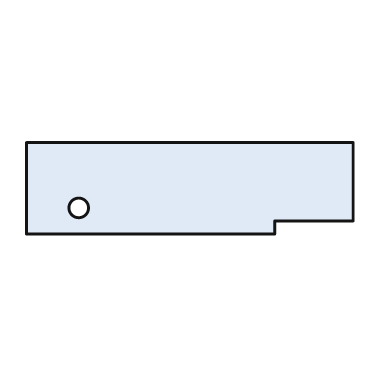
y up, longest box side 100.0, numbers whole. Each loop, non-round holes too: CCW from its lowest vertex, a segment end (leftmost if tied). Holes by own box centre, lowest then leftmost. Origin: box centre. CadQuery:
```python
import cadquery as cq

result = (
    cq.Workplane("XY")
    .moveTo(-50.0, -14.0)
    .lineTo(26.0, -14.0)
    .lineTo(26.0, -10.0)
    .lineTo(50.0, -10.0)
    .lineTo(50.0, 14.0)
    .lineTo(-50.0, 14.0)
    .close()
    .moveTo(-34.0, -6.0)
    .circle(3.0)
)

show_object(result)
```